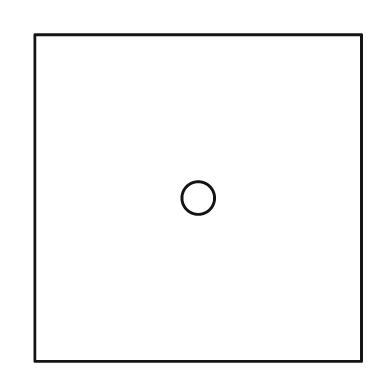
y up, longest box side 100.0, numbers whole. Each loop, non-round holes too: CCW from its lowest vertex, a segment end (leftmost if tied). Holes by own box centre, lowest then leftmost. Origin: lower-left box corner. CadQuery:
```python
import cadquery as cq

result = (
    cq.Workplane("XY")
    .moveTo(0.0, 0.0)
    .lineTo(100.0, 0.0)
    .lineTo(100.0, 100.0)
    .lineTo(0.0, 100.0)
    .close()
    .moveTo(50.0, 50.0)
    .circle(5.0)
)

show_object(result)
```